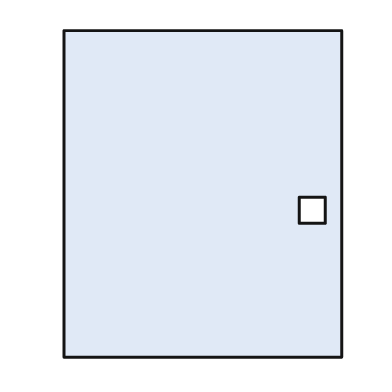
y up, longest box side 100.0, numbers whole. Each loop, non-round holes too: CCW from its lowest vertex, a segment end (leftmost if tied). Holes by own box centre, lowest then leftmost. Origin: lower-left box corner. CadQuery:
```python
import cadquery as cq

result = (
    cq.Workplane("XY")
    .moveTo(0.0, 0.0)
    .lineTo(85.0, 0.0)
    .lineTo(85.0, 100.0)
    .lineTo(0.0, 100.0)
    .close()
    .moveTo(72.0, 41.0)
    .lineTo(80.0, 41.0)
    .lineTo(80.0, 49.0)
    .lineTo(72.0, 49.0)
    .close()
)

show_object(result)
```